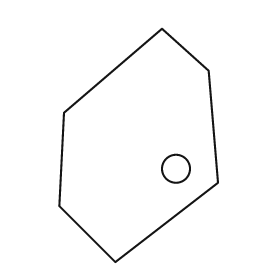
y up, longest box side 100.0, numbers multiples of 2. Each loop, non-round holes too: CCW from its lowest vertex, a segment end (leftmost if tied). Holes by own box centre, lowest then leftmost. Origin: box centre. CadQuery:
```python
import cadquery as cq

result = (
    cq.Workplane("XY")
    .moveTo(-10.0, -50.0)
    .lineTo(34.0, -16.0)
    .lineTo(30.0, 32.0)
    .lineTo(10.0, 50.0)
    .lineTo(-32.0, 14.0)
    .lineTo(-34.0, -26.0)
    .close()
    .moveTo(16.0, -10.0)
    .circle(6.0)
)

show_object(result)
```